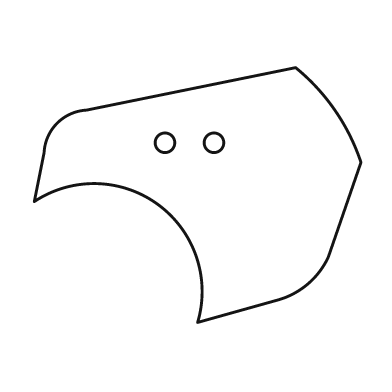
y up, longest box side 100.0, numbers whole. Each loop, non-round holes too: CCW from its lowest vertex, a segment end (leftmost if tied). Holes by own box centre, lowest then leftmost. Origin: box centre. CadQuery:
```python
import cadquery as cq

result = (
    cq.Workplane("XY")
    .moveTo(0.0, -39.0)
    .lineTo(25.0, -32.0)
    .threePointArc((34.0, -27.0), (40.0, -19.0))
    .lineTo(50.0, 10.0)
    .threePointArc((42.0, 26.0), (30.0, 39.0))
    .lineTo(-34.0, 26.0)
    .threePointArc((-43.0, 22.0), (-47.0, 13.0))
    .lineTo(-50.0, -2.0)
    .threePointArc((-12.0, -3.0), (0.0, -39.0))
    .close()
    .moveTo(-10.0, 16.0)
    .circle(3.0)
    .moveTo(5.0, 16.0)
    .circle(3.0)
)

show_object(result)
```